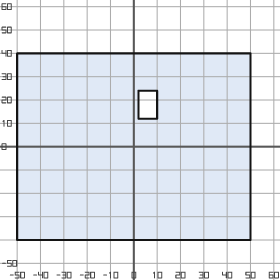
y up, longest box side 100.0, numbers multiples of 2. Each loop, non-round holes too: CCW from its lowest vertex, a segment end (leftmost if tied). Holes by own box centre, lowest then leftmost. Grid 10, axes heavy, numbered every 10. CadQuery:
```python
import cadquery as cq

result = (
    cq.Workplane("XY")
    .moveTo(-50.0, -40.0)
    .lineTo(50.0, -40.0)
    .lineTo(50.0, 40.0)
    .lineTo(-50.0, 40.0)
    .close()
    .moveTo(2.0, 12.0)
    .lineTo(10.0, 12.0)
    .lineTo(10.0, 24.0)
    .lineTo(2.0, 24.0)
    .close()
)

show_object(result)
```